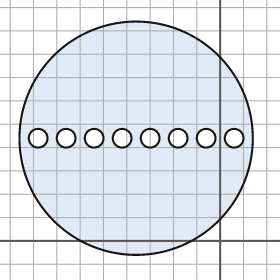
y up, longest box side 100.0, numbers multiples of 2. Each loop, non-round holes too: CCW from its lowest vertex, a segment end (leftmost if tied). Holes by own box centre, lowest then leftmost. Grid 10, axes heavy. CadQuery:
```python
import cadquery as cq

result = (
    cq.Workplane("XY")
    .moveTo(-36.0, 44.0)
    .circle(50.0)
    .moveTo(-78.0, 44.0)
    .circle(4.0)
    .moveTo(-66.0, 44.0)
    .circle(4.0)
    .moveTo(-54.0, 44.0)
    .circle(4.0)
    .moveTo(-42.0, 44.0)
    .circle(4.0)
    .moveTo(-30.0, 44.0)
    .circle(4.0)
    .moveTo(-18.0, 44.0)
    .circle(4.0)
    .moveTo(-6.0, 44.0)
    .circle(4.0)
    .moveTo(6.0, 44.0)
    .circle(4.0)
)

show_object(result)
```